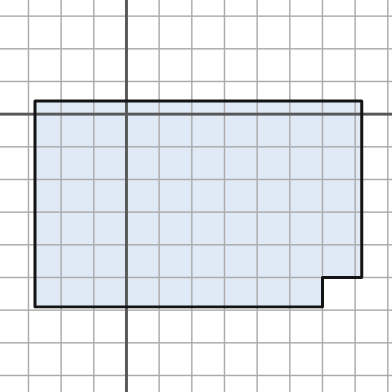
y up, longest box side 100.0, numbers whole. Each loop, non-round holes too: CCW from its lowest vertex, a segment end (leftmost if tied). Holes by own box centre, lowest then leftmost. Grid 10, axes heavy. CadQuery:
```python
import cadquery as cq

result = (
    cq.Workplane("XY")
    .moveTo(-28.0, -59.0)
    .lineTo(60.0, -59.0)
    .lineTo(60.0, -50.0)
    .lineTo(72.0, -50.0)
    .lineTo(72.0, 4.0)
    .lineTo(-28.0, 4.0)
    .close()
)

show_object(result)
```